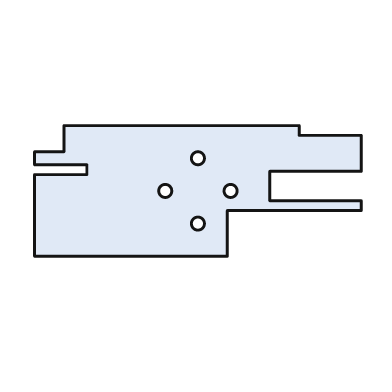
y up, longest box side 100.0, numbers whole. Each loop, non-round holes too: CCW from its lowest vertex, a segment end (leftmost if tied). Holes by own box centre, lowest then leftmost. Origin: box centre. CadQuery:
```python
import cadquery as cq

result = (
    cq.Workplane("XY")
    .moveTo(-50.0, -20.0)
    .lineTo(9.0, -20.0)
    .lineTo(9.0, -6.0)
    .lineTo(50.0, -6.0)
    .lineTo(50.0, -3.0)
    .lineTo(22.0, -3.0)
    .lineTo(22.0, 6.0)
    .lineTo(50.0, 6.0)
    .lineTo(50.0, 17.0)
    .lineTo(31.0, 17.0)
    .lineTo(31.0, 20.0)
    .lineTo(-41.0, 20.0)
    .lineTo(-41.0, 12.0)
    .lineTo(-50.0, 12.0)
    .lineTo(-50.0, 8.0)
    .lineTo(-34.0, 8.0)
    .lineTo(-34.0, 5.0)
    .lineTo(-50.0, 5.0)
    .close()
    .moveTo(0.0, -10.0)
    .circle(2.0)
    .moveTo(-10.0, 0.0)
    .circle(2.0)
    .moveTo(10.0, 0.0)
    .circle(2.0)
    .moveTo(0.0, 10.0)
    .circle(2.0)
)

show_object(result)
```